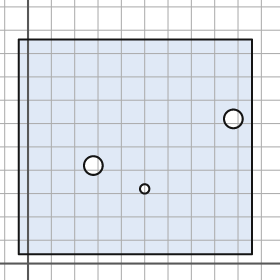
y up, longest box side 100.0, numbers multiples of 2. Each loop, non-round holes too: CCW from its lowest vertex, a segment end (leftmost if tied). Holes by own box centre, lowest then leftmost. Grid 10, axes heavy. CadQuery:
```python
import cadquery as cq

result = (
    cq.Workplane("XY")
    .moveTo(-4.0, 4.0)
    .lineTo(96.0, 4.0)
    .lineTo(96.0, 96.0)
    .lineTo(-4.0, 96.0)
    .close()
    .moveTo(50.0, 32.0)
    .circle(2.0)
    .moveTo(28.0, 42.0)
    .circle(4.0)
    .moveTo(88.0, 62.0)
    .circle(4.0)
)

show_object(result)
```